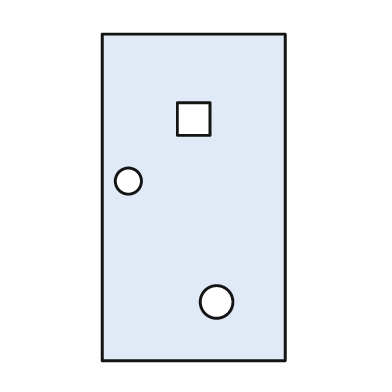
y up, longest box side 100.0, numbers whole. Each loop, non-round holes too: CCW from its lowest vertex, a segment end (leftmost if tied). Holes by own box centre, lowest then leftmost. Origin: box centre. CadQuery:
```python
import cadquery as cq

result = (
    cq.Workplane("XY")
    .moveTo(-28.0, -50.0)
    .lineTo(28.0, -50.0)
    .lineTo(28.0, 50.0)
    .lineTo(-28.0, 50.0)
    .close()
    .moveTo(7.0, -32.0)
    .circle(5.0)
    .moveTo(-20.0, 5.0)
    .circle(4.0)
    .moveTo(-5.0, 19.0)
    .lineTo(5.0, 19.0)
    .lineTo(5.0, 29.0)
    .lineTo(-5.0, 29.0)
    .close()
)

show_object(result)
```